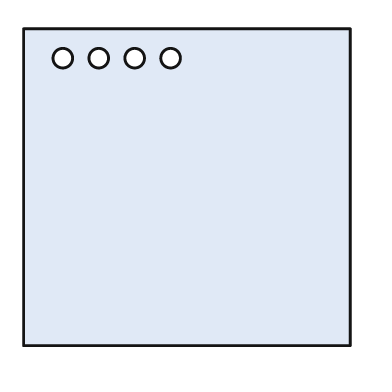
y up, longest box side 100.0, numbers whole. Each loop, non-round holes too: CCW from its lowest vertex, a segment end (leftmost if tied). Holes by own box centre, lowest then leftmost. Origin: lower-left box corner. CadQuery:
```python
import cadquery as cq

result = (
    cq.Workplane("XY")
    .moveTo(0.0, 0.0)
    .lineTo(100.0, 0.0)
    .lineTo(100.0, 97.0)
    .lineTo(0.0, 97.0)
    .close()
    .moveTo(12.0, 88.0)
    .circle(3.0)
    .moveTo(23.0, 88.0)
    .circle(3.0)
    .moveTo(34.0, 88.0)
    .circle(3.0)
    .moveTo(45.0, 88.0)
    .circle(3.0)
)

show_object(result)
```